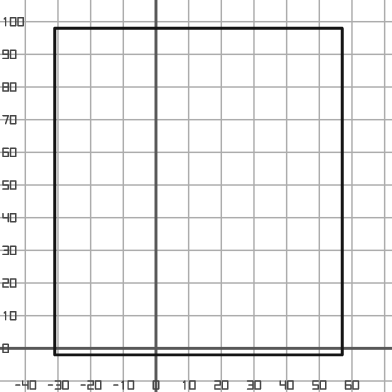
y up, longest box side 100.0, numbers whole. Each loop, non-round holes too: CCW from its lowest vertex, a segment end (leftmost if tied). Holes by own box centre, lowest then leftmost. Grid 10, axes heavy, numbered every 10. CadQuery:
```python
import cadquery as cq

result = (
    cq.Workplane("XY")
    .moveTo(-31.0, -2.0)
    .lineTo(57.0, -2.0)
    .lineTo(57.0, 98.0)
    .lineTo(-31.0, 98.0)
    .close()
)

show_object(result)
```